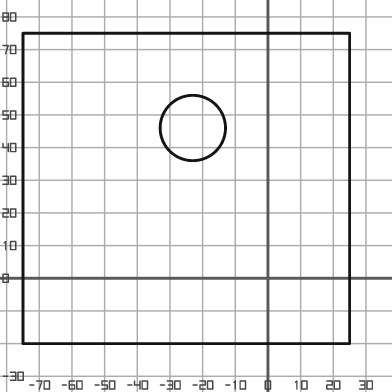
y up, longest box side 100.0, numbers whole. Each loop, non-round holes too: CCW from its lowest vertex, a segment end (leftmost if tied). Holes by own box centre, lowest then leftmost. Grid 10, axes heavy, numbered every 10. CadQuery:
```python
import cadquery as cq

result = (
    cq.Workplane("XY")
    .moveTo(-75.0, -20.0)
    .lineTo(25.0, -20.0)
    .lineTo(25.0, 75.0)
    .lineTo(-75.0, 75.0)
    .close()
    .moveTo(-23.0, 46.0)
    .circle(10.0)
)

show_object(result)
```